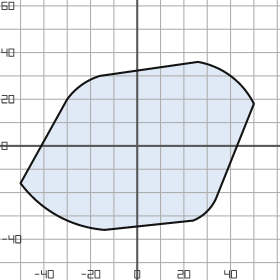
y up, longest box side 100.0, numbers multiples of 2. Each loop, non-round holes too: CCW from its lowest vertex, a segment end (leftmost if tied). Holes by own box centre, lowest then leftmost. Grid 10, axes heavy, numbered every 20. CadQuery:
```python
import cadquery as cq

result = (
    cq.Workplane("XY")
    .moveTo(-14.0, -36.0)
    .lineTo(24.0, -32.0)
    .threePointArc((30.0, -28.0), (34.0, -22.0))
    .lineTo(50.0, 18.0)
    .threePointArc((40.0, 30.0), (26.0, 36.0))
    .lineTo(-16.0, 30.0)
    .threePointArc((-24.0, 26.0), (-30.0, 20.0))
    .lineTo(-50.0, -16.0)
    .threePointArc((-34.0, -30.0), (-14.0, -36.0))
    .close()
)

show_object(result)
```